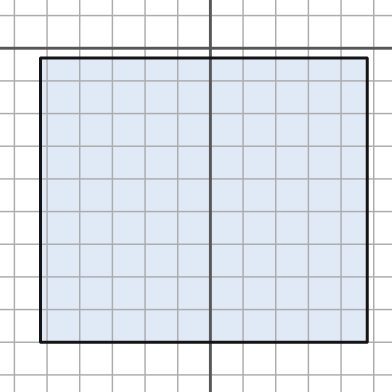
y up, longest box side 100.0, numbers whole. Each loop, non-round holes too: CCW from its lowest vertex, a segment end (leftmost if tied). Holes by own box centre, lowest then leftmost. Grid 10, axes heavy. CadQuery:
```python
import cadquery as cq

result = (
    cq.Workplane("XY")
    .moveTo(-52.0, -90.0)
    .lineTo(48.0, -90.0)
    .lineTo(48.0, -3.0)
    .lineTo(-52.0, -3.0)
    .close()
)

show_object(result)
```